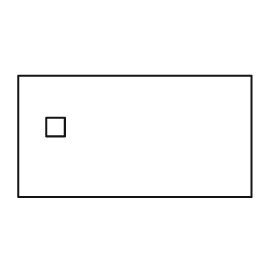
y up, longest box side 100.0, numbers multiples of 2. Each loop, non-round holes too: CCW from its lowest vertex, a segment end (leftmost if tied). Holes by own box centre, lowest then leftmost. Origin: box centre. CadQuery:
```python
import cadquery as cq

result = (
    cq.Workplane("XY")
    .moveTo(-50.0, -26.0)
    .lineTo(50.0, -26.0)
    .lineTo(50.0, 26.0)
    .lineTo(-50.0, 26.0)
    .close()
    .moveTo(-38.0, 0.0)
    .lineTo(-30.0, 0.0)
    .lineTo(-30.0, 8.0)
    .lineTo(-38.0, 8.0)
    .close()
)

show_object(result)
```